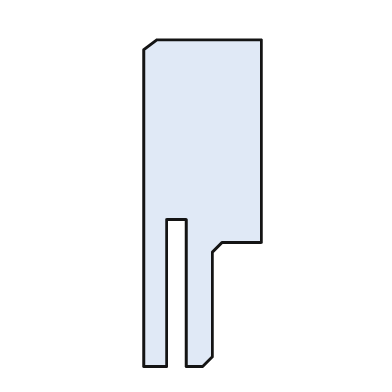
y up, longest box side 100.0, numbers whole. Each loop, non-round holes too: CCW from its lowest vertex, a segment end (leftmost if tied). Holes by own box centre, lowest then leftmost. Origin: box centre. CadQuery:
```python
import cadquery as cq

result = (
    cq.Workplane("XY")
    .moveTo(-18.0, -50.0)
    .lineTo(-11.0, -50.0)
    .lineTo(-11.0, -5.0)
    .lineTo(-5.0, -5.0)
    .lineTo(-5.0, -50.0)
    .lineTo(0.0, -50.0)
    .lineTo(3.0, -47.0)
    .lineTo(3.0, -15.0)
    .lineTo(6.0, -12.0)
    .lineTo(18.0, -12.0)
    .lineTo(18.0, 50.0)
    .lineTo(-14.0, 50.0)
    .lineTo(-18.0, 47.0)
    .close()
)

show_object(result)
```